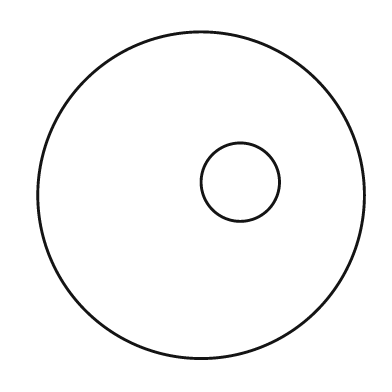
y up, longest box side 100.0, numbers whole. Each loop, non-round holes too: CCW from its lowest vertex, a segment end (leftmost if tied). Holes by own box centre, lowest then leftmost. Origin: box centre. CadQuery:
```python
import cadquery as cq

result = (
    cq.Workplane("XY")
    .moveTo(0.0, 0.0)
    .circle(50.0)
    .moveTo(12.0, 4.0)
    .circle(12.0)
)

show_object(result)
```